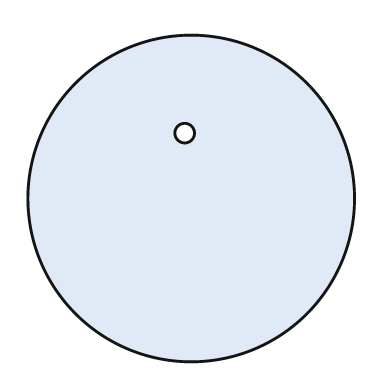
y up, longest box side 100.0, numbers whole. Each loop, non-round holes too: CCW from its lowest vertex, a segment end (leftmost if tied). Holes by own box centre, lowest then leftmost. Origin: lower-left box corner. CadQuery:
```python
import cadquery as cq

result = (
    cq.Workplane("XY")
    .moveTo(50.0, 50.0)
    .circle(50.0)
    .moveTo(48.0, 70.0)
    .circle(3.0)
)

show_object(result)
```